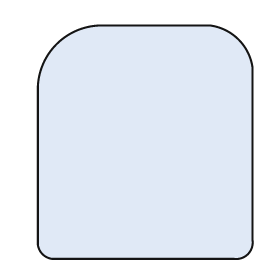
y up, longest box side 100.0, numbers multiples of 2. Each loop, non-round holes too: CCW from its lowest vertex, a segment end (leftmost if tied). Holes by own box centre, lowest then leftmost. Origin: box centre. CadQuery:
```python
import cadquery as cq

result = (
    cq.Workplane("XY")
    .moveTo(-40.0, -50.0)
    .lineTo(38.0, -50.0)
    .threePointArc((44.0, -48.0), (46.0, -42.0))
    .lineTo(46.0, 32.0)
    .threePointArc((40.0, 44.0), (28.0, 50.0))
    .lineTo(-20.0, 50.0)
    .threePointArc((-38.0, 42.0), (-46.0, 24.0))
    .lineTo(-46.0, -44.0)
    .threePointArc((-44.0, -48.0), (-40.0, -50.0))
    .close()
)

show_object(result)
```